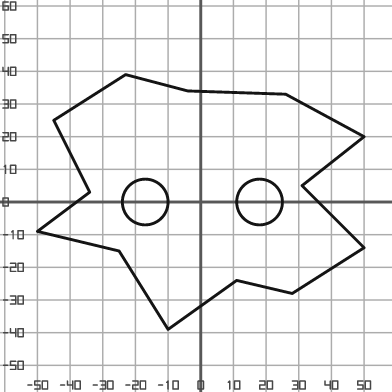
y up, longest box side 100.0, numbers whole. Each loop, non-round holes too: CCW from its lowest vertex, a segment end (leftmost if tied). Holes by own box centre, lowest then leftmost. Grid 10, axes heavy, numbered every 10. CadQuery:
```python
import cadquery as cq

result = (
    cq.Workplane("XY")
    .moveTo(-10.0, -39.0)
    .lineTo(11.0, -24.0)
    .lineTo(28.0, -28.0)
    .lineTo(50.0, -14.0)
    .lineTo(31.0, 5.0)
    .lineTo(50.0, 20.0)
    .lineTo(26.0, 33.0)
    .lineTo(-4.0, 34.0)
    .lineTo(-23.0, 39.0)
    .lineTo(-45.0, 25.0)
    .lineTo(-34.0, 3.0)
    .lineTo(-50.0, -9.0)
    .lineTo(-25.0, -15.0)
    .close()
    .moveTo(-17.0, 0.0)
    .circle(7.0)
    .moveTo(18.0, 0.0)
    .circle(7.0)
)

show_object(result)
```